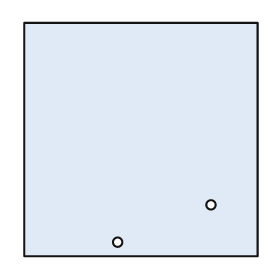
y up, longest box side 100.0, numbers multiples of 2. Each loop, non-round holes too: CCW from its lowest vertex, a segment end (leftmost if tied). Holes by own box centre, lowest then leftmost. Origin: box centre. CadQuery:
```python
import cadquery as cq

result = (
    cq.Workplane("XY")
    .moveTo(-50.0, -50.0)
    .lineTo(50.0, -50.0)
    .lineTo(50.0, 50.0)
    .lineTo(-50.0, 50.0)
    .close()
    .moveTo(-10.0, -44.0)
    .circle(2.0)
    .moveTo(30.0, -28.0)
    .circle(2.0)
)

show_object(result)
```